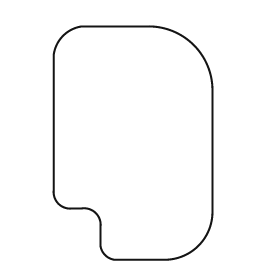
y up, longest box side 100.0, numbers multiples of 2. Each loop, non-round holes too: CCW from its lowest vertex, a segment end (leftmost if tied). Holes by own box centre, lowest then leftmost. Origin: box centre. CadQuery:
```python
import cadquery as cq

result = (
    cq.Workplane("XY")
    .moveTo(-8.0, -50.0)
    .lineTo(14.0, -50.0)
    .threePointArc((28.0, -44.0), (34.0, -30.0))
    .lineTo(34.0, 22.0)
    .threePointArc((26.0, 42.0), (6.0, 50.0))
    .lineTo(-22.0, 50.0)
    .threePointArc((-30.0, 46.0), (-34.0, 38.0))
    .lineTo(-34.0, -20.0)
    .threePointArc((-32.0, -26.0), (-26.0, -28.0))
    .lineTo(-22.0, -28.0)
    .threePointArc((-16.0, -30.0), (-14.0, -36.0))
    .lineTo(-14.0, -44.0)
    .threePointArc((-12.0, -48.0), (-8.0, -50.0))
    .close()
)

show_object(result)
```